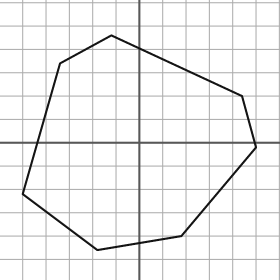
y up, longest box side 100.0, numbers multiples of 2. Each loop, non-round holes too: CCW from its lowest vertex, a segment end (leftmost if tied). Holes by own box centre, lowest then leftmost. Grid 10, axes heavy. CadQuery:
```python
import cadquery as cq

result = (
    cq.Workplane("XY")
    .moveTo(-18.0, -46.0)
    .lineTo(18.0, -40.0)
    .lineTo(50.0, -2.0)
    .lineTo(44.0, 20.0)
    .lineTo(-12.0, 46.0)
    .lineTo(-34.0, 34.0)
    .lineTo(-50.0, -22.0)
    .close()
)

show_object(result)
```